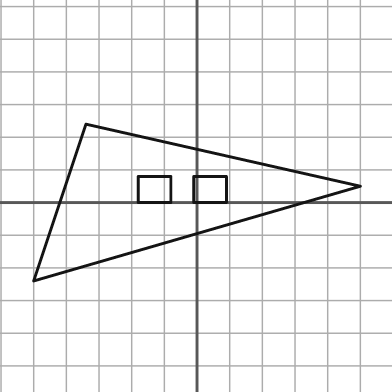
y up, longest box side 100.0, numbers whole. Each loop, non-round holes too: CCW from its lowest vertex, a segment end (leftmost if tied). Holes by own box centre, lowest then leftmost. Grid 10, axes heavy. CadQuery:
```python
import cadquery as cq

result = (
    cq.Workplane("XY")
    .moveTo(-50.0, -24.0)
    .lineTo(50.0, 5.0)
    .lineTo(-34.0, 24.0)
    .close()
    .moveTo(-18.0, 0.0)
    .lineTo(-8.0, 0.0)
    .lineTo(-8.0, 8.0)
    .lineTo(-18.0, 8.0)
    .close()
    .moveTo(-1.0, 0.0)
    .lineTo(9.0, 0.0)
    .lineTo(9.0, 8.0)
    .lineTo(-1.0, 8.0)
    .close()
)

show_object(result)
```